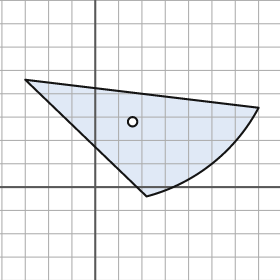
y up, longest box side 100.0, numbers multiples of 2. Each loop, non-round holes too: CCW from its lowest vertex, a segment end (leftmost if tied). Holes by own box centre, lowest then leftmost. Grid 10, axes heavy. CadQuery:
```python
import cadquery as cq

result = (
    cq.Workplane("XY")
    .moveTo(22.0, -4.0)
    .threePointArc((50.0, 10.0), (70.0, 34.0))
    .lineTo(-30.0, 46.0)
    .close()
    .moveTo(16.0, 28.0)
    .circle(2.0)
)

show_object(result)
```